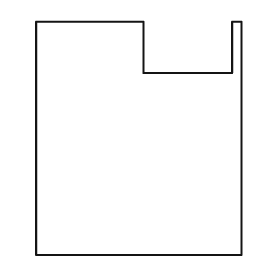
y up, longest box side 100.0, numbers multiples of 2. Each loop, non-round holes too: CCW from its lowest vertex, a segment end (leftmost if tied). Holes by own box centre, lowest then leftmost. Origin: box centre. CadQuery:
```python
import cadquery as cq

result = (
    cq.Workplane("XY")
    .moveTo(-44.0, -50.0)
    .lineTo(44.0, -50.0)
    .lineTo(44.0, 50.0)
    .lineTo(40.0, 50.0)
    .lineTo(40.0, 28.0)
    .lineTo(2.0, 28.0)
    .lineTo(2.0, 50.0)
    .lineTo(-44.0, 50.0)
    .close()
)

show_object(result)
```